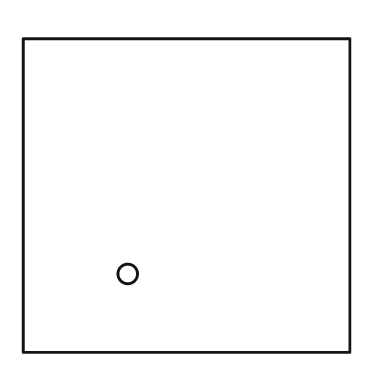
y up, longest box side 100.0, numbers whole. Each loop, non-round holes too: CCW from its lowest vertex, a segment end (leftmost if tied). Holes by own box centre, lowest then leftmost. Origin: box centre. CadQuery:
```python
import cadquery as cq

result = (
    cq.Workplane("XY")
    .moveTo(-50.0, -48.0)
    .lineTo(50.0, -48.0)
    .lineTo(50.0, 48.0)
    .lineTo(-50.0, 48.0)
    .close()
    .moveTo(-18.0, -24.0)
    .circle(3.0)
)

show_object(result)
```